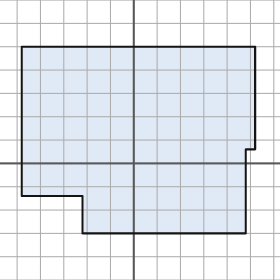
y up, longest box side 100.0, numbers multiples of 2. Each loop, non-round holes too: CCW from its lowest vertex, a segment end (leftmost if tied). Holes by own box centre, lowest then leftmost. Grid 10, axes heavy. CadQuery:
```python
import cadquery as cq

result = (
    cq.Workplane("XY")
    .moveTo(-22.0, -30.0)
    .lineTo(48.0, -30.0)
    .lineTo(48.0, 6.0)
    .lineTo(52.0, 6.0)
    .lineTo(52.0, 50.0)
    .lineTo(-48.0, 50.0)
    .lineTo(-48.0, -14.0)
    .lineTo(-22.0, -14.0)
    .close()
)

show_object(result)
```